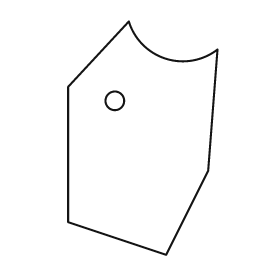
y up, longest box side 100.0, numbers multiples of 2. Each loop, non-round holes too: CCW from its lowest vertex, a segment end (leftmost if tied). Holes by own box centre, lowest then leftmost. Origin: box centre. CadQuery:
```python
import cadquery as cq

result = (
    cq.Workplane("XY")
    .moveTo(10.0, -50.0)
    .lineTo(28.0, -14.0)
    .lineTo(32.0, 38.0)
    .threePointArc((10.0, 34.0), (-6.0, 50.0))
    .lineTo(-32.0, 22.0)
    .lineTo(-32.0, -36.0)
    .close()
    .moveTo(-12.0, 16.0)
    .circle(4.0)
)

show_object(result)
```